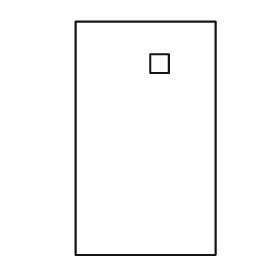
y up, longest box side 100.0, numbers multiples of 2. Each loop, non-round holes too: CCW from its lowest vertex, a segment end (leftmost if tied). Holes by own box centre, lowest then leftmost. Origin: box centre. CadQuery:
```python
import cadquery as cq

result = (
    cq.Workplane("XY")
    .moveTo(-30.0, -50.0)
    .lineTo(30.0, -50.0)
    .lineTo(30.0, 50.0)
    .lineTo(-30.0, 50.0)
    .close()
    .moveTo(2.0, 28.0)
    .lineTo(10.0, 28.0)
    .lineTo(10.0, 36.0)
    .lineTo(2.0, 36.0)
    .close()
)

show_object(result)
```